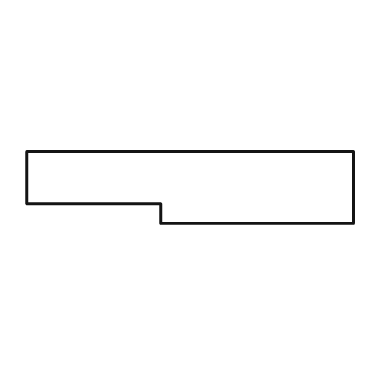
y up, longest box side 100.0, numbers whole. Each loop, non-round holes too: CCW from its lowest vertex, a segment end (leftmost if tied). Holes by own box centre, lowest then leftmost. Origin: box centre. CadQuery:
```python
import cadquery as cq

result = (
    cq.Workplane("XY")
    .moveTo(-9.0, -11.0)
    .lineTo(50.0, -11.0)
    .lineTo(50.0, 11.0)
    .lineTo(-50.0, 11.0)
    .lineTo(-50.0, -5.0)
    .lineTo(-9.0, -5.0)
    .close()
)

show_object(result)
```